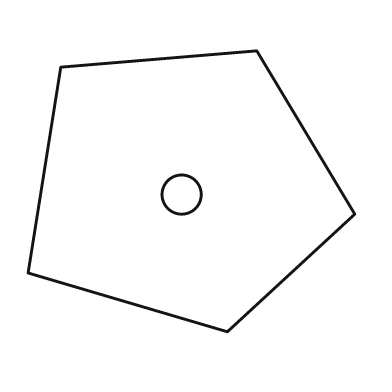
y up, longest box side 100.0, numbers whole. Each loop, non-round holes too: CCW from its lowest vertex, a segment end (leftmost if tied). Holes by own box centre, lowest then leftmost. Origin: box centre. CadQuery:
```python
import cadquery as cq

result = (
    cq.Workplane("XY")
    .moveTo(11.0, -43.0)
    .lineTo(50.0, -7.0)
    .lineTo(20.0, 43.0)
    .lineTo(-40.0, 38.0)
    .lineTo(-50.0, -25.0)
    .close()
    .moveTo(-3.0, -1.0)
    .circle(6.0)
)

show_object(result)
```